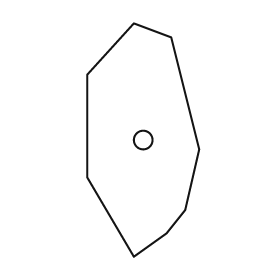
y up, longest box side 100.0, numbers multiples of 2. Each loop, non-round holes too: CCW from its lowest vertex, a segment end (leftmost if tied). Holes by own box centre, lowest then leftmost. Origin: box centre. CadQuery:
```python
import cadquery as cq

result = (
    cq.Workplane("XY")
    .moveTo(-4.0, -50.0)
    .lineTo(10.0, -40.0)
    .lineTo(18.0, -30.0)
    .lineTo(24.0, -4.0)
    .lineTo(12.0, 44.0)
    .lineTo(-4.0, 50.0)
    .lineTo(-24.0, 28.0)
    .lineTo(-24.0, -16.0)
    .close()
    .moveTo(0.0, 0.0)
    .circle(4.0)
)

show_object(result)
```